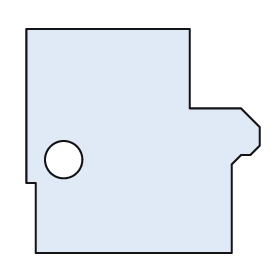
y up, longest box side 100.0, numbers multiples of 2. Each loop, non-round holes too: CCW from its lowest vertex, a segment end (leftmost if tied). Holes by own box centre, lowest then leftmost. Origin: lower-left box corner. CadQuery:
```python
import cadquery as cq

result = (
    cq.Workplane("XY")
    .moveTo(4.0, 0.0)
    .lineTo(88.0, 0.0)
    .lineTo(88.0, 38.0)
    .lineTo(92.0, 42.0)
    .lineTo(96.0, 42.0)
    .lineTo(100.0, 46.0)
    .lineTo(100.0, 54.0)
    .lineTo(92.0, 62.0)
    .lineTo(70.0, 62.0)
    .lineTo(70.0, 96.0)
    .lineTo(0.0, 96.0)
    .lineTo(0.0, 30.0)
    .lineTo(4.0, 30.0)
    .close()
    .moveTo(16.0, 40.0)
    .circle(8.0)
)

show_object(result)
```